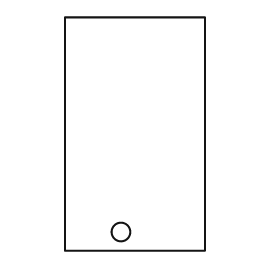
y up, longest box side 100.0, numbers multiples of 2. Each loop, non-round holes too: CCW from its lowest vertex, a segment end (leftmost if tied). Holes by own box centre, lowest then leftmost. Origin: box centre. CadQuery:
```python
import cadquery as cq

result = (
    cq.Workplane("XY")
    .moveTo(-30.0, -50.0)
    .lineTo(30.0, -50.0)
    .lineTo(30.0, 50.0)
    .lineTo(-30.0, 50.0)
    .close()
    .moveTo(-6.0, -42.0)
    .circle(4.0)
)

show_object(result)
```